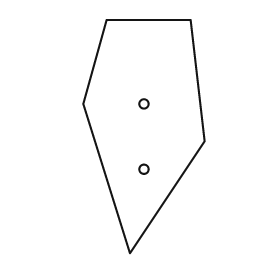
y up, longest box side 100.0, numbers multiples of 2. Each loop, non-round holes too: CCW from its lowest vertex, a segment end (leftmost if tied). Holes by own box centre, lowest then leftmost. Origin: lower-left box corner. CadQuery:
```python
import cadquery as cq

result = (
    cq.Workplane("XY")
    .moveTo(20.0, 0.0)
    .lineTo(52.0, 48.0)
    .lineTo(46.0, 100.0)
    .lineTo(10.0, 100.0)
    .lineTo(0.0, 64.0)
    .close()
    .moveTo(26.0, 36.0)
    .circle(2.0)
    .moveTo(26.0, 64.0)
    .circle(2.0)
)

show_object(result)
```